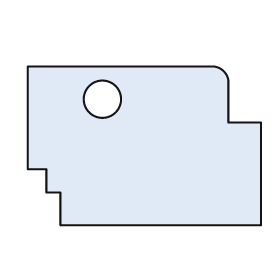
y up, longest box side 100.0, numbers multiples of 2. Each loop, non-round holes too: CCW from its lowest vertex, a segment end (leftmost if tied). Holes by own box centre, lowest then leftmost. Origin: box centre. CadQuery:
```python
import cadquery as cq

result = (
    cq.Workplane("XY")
    .moveTo(-36.0, -34.0)
    .lineTo(50.0, -34.0)
    .lineTo(50.0, 10.0)
    .lineTo(36.0, 10.0)
    .lineTo(36.0, 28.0)
    .threePointArc((34.0, 32.0), (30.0, 34.0))
    .lineTo(-50.0, 34.0)
    .lineTo(-50.0, -10.0)
    .lineTo(-42.0, -10.0)
    .lineTo(-42.0, -20.0)
    .lineTo(-36.0, -20.0)
    .close()
    .moveTo(-18.0, 20.0)
    .circle(8.0)
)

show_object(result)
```